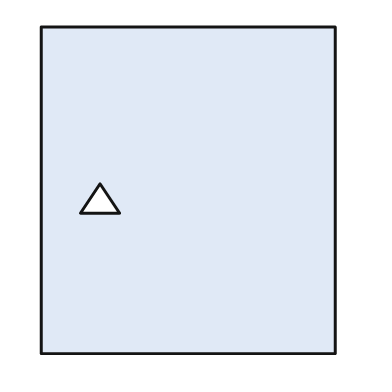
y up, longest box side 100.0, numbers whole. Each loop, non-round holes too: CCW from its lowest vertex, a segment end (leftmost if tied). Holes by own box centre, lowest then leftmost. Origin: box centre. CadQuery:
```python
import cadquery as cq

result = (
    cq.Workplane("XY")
    .moveTo(-45.0, -50.0)
    .lineTo(45.0, -50.0)
    .lineTo(45.0, 50.0)
    .lineTo(-45.0, 50.0)
    .close()
    .moveTo(-33.0, -7.0)
    .lineTo(-21.0, -7.0)
    .lineTo(-27.0, 2.0)
    .close()
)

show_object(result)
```